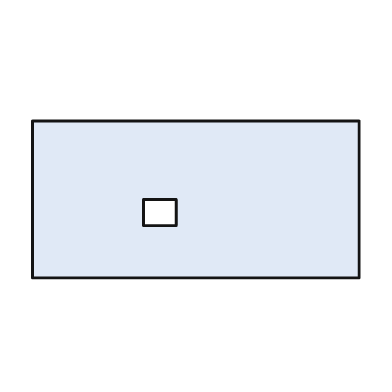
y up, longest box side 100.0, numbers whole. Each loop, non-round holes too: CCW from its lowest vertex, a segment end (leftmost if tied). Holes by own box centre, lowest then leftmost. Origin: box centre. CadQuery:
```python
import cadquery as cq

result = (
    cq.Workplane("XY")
    .moveTo(-50.0, -24.0)
    .lineTo(50.0, -24.0)
    .lineTo(50.0, 24.0)
    .lineTo(-50.0, 24.0)
    .close()
    .moveTo(-16.0, -8.0)
    .lineTo(-6.0, -8.0)
    .lineTo(-6.0, 0.0)
    .lineTo(-16.0, 0.0)
    .close()
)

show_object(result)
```